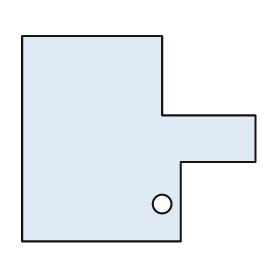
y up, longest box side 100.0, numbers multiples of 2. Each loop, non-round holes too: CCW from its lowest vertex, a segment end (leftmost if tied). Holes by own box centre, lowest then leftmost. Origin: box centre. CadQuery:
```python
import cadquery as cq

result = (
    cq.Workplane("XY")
    .moveTo(-50.0, -44.0)
    .lineTo(18.0, -44.0)
    .lineTo(18.0, -10.0)
    .lineTo(50.0, -10.0)
    .lineTo(50.0, 10.0)
    .lineTo(10.0, 10.0)
    .lineTo(10.0, 44.0)
    .lineTo(-50.0, 44.0)
    .close()
    .moveTo(10.0, -28.0)
    .circle(4.0)
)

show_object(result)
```